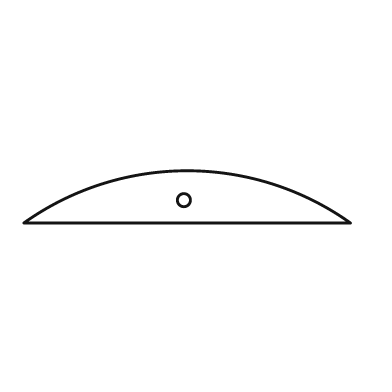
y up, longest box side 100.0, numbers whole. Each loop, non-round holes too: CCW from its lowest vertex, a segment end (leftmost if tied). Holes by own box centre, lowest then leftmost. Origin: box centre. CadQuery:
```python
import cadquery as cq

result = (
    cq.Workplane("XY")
    .moveTo(-50.0, -8.0)
    .lineTo(50.0, -8.0)
    .threePointArc((0.0, 8.0), (-50.0, -8.0))
    .close()
    .moveTo(-1.0, -1.0)
    .circle(2.0)
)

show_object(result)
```